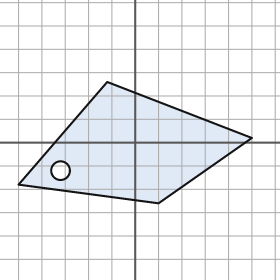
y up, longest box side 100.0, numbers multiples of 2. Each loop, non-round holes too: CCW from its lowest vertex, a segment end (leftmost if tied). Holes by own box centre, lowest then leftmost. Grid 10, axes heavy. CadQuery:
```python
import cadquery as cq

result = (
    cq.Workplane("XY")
    .moveTo(10.0, -26.0)
    .lineTo(50.0, 2.0)
    .lineTo(-12.0, 26.0)
    .lineTo(-50.0, -18.0)
    .close()
    .moveTo(-32.0, -12.0)
    .circle(4.0)
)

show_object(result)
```